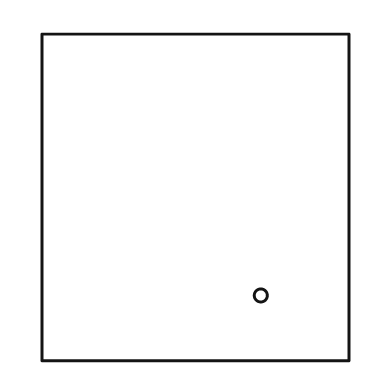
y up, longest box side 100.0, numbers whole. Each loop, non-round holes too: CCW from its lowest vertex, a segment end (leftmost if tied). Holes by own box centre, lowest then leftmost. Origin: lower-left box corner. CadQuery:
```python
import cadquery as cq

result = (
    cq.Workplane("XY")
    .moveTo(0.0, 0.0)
    .lineTo(94.0, 0.0)
    .lineTo(94.0, 100.0)
    .lineTo(0.0, 100.0)
    .close()
    .moveTo(67.0, 20.0)
    .circle(2.0)
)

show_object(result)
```